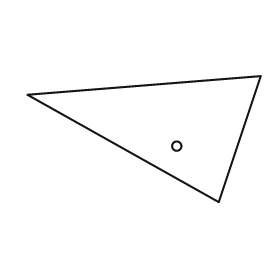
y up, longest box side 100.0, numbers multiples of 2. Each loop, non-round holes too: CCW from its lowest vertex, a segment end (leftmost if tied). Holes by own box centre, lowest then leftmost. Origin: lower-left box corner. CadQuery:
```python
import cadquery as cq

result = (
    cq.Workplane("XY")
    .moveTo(82.0, 0.0)
    .lineTo(100.0, 54.0)
    .lineTo(0.0, 46.0)
    .close()
    .moveTo(64.0, 24.0)
    .circle(2.0)
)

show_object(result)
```